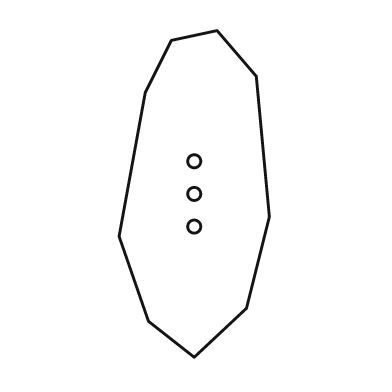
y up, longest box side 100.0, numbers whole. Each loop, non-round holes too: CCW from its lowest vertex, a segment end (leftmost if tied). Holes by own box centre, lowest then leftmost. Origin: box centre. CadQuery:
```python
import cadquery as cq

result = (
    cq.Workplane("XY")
    .moveTo(0.0, -50.0)
    .lineTo(16.0, -35.0)
    .lineTo(23.0, -7.0)
    .lineTo(19.0, 36.0)
    .lineTo(7.0, 50.0)
    .lineTo(-7.0, 47.0)
    .lineTo(-15.0, 31.0)
    .lineTo(-23.0, -13.0)
    .lineTo(-14.0, -39.0)
    .close()
    .moveTo(0.0, -10.0)
    .circle(2.0)
    .moveTo(0.0, 0.0)
    .circle(2.0)
    .moveTo(0.0, 10.0)
    .circle(2.0)
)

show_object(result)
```